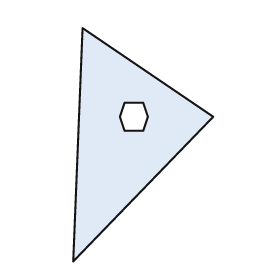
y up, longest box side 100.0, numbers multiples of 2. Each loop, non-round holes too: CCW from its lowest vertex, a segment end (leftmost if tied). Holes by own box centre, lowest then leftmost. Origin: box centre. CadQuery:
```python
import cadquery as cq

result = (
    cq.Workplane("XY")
    .moveTo(-30.0, -50.0)
    .lineTo(30.0, 12.0)
    .lineTo(-26.0, 50.0)
    .close()
    .moveTo(-8.0, 6.0)
    .lineTo(0.0, 6.0)
    .lineTo(2.0, 12.0)
    .lineTo(0.0, 18.0)
    .lineTo(-8.0, 18.0)
    .lineTo(-10.0, 12.0)
    .close()
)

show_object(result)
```